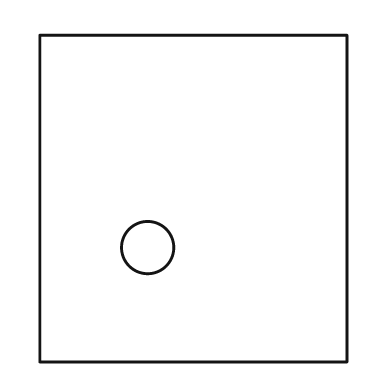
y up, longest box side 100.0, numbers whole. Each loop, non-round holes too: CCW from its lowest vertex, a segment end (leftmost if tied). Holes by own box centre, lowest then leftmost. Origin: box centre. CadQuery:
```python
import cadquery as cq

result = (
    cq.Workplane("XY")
    .moveTo(-47.0, -50.0)
    .lineTo(47.0, -50.0)
    .lineTo(47.0, 50.0)
    .lineTo(-47.0, 50.0)
    .close()
    .moveTo(-14.0, -15.0)
    .circle(8.0)
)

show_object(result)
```